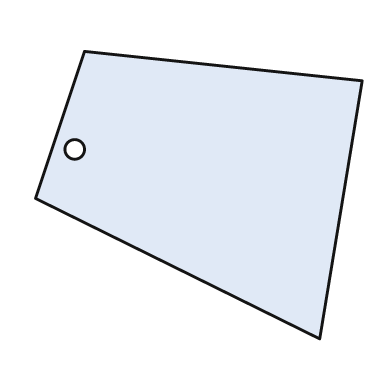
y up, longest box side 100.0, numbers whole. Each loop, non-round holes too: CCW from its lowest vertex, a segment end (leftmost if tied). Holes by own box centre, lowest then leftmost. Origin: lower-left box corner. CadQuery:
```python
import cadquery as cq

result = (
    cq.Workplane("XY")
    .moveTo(87.0, 0.0)
    .lineTo(100.0, 79.0)
    .lineTo(15.0, 88.0)
    .lineTo(0.0, 43.0)
    .close()
    .moveTo(12.0, 58.0)
    .circle(3.0)
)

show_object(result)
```